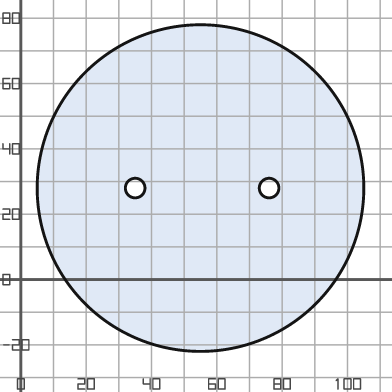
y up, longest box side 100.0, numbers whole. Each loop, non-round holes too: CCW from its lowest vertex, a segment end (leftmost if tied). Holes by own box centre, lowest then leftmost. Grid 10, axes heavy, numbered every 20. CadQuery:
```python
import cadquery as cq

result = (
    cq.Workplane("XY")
    .moveTo(55.0, 28.0)
    .circle(50.0)
    .moveTo(35.0, 28.0)
    .circle(3.0)
    .moveTo(76.0, 28.0)
    .circle(3.0)
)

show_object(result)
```